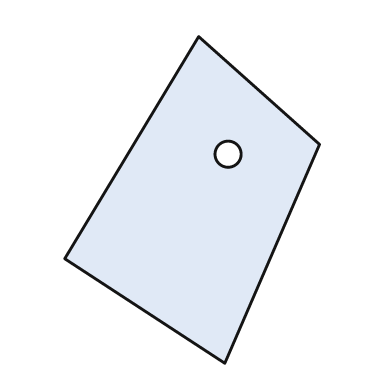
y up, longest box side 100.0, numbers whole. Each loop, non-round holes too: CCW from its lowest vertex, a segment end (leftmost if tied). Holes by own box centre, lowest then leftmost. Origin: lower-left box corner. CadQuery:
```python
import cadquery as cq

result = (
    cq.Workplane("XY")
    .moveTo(49.0, 0.0)
    .lineTo(78.0, 67.0)
    .lineTo(41.0, 100.0)
    .lineTo(0.0, 32.0)
    .close()
    .moveTo(50.0, 64.0)
    .circle(4.0)
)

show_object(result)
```